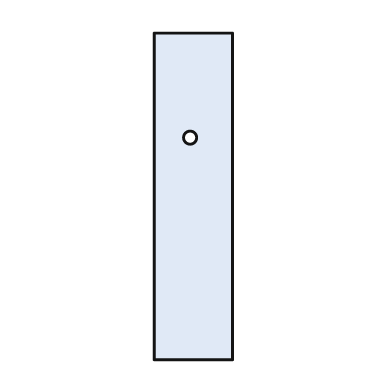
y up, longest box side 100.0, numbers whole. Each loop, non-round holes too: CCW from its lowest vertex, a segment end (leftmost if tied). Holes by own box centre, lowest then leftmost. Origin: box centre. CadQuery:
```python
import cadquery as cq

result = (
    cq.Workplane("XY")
    .moveTo(-12.0, -50.0)
    .lineTo(12.0, -50.0)
    .lineTo(12.0, 50.0)
    .lineTo(-12.0, 50.0)
    .close()
    .moveTo(-1.0, 18.0)
    .circle(2.0)
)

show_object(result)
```